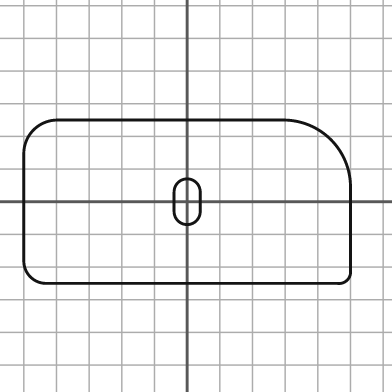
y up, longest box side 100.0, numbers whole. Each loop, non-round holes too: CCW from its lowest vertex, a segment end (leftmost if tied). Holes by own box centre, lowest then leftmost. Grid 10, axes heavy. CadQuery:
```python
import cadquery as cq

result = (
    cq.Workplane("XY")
    .moveTo(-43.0, -25.0)
    .lineTo(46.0, -25.0)
    .threePointArc((49.0, -24.0), (50.0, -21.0))
    .lineTo(50.0, 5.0)
    .threePointArc((44.0, 19.0), (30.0, 25.0))
    .lineTo(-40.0, 25.0)
    .threePointArc((-47.0, 22.0), (-50.0, 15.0))
    .lineTo(-50.0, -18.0)
    .threePointArc((-48.0, -23.0), (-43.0, -25.0))
    .close()
    .moveTo(-4.0, -3.0)
    .threePointArc((0.0, -7.0), (4.0, -3.0))
    .lineTo(4.0, 3.0)
    .threePointArc((0.0, 7.0), (-4.0, 3.0))
    .close()
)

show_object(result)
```